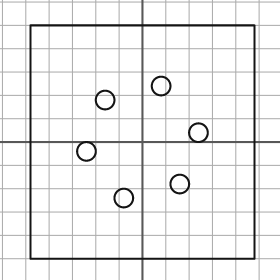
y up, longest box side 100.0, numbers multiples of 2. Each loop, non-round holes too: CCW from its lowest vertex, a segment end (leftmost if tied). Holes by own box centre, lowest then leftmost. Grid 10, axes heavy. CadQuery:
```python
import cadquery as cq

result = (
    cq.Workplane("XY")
    .moveTo(-48.0, -50.0)
    .lineTo(48.0, -50.0)
    .lineTo(48.0, 50.0)
    .lineTo(-48.0, 50.0)
    .close()
    .moveTo(-8.0, -24.0)
    .circle(4.0)
    .moveTo(16.0, -18.0)
    .circle(4.0)
    .moveTo(-24.0, -4.0)
    .circle(4.0)
    .moveTo(24.0, 4.0)
    .circle(4.0)
    .moveTo(-16.0, 18.0)
    .circle(4.0)
    .moveTo(8.0, 24.0)
    .circle(4.0)
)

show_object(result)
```